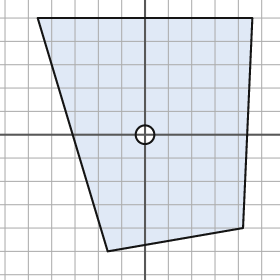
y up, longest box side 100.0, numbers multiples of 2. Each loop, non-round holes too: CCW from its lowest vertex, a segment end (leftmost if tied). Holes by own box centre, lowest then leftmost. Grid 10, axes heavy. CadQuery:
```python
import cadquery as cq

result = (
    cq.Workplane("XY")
    .moveTo(-16.0, -50.0)
    .lineTo(42.0, -40.0)
    .lineTo(46.0, 50.0)
    .lineTo(-46.0, 50.0)
    .close()
    .moveTo(0.0, 0.0)
    .circle(4.0)
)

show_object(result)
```